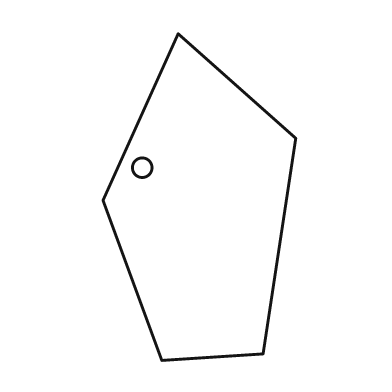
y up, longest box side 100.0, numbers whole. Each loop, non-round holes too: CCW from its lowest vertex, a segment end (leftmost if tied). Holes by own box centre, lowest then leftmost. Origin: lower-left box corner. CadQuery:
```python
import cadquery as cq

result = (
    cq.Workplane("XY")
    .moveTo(18.0, 0.0)
    .lineTo(49.0, 2.0)
    .lineTo(59.0, 68.0)
    .lineTo(23.0, 100.0)
    .lineTo(0.0, 49.0)
    .close()
    .moveTo(12.0, 59.0)
    .circle(3.0)
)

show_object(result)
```